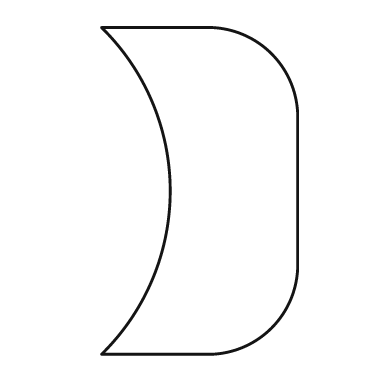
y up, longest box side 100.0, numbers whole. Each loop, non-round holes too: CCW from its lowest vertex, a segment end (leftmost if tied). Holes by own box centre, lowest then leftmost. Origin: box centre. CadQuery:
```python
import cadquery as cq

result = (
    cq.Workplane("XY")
    .moveTo(-30.0, -50.0)
    .lineTo(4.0, -50.0)
    .threePointArc((22.0, -42.0), (30.0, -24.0))
    .lineTo(30.0, 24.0)
    .threePointArc((22.0, 42.0), (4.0, 50.0))
    .lineTo(-30.0, 50.0)
    .threePointArc((-9.0, 0.0), (-30.0, -50.0))
    .close()
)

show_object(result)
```